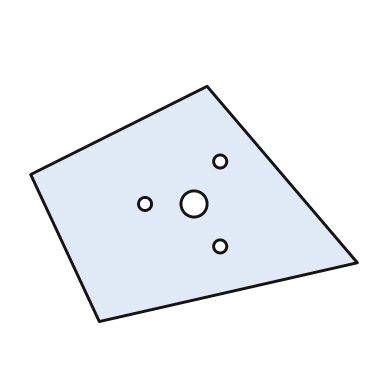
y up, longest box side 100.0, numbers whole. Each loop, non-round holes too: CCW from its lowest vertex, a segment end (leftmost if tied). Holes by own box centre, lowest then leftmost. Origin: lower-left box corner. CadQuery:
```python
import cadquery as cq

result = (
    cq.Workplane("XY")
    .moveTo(21.0, 0.0)
    .lineTo(100.0, 18.0)
    .lineTo(54.0, 72.0)
    .lineTo(0.0, 45.0)
    .close()
    .moveTo(58.0, 23.0)
    .circle(2.0)
    .moveTo(35.0, 36.0)
    .circle(2.0)
    .moveTo(50.0, 36.0)
    .circle(4.0)
    .moveTo(58.0, 49.0)
    .circle(2.0)
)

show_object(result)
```